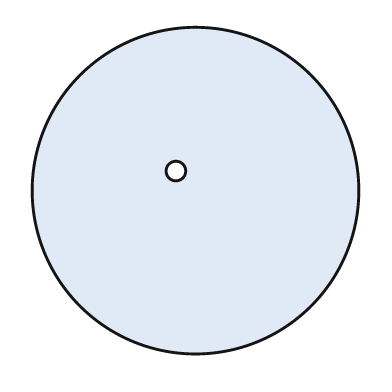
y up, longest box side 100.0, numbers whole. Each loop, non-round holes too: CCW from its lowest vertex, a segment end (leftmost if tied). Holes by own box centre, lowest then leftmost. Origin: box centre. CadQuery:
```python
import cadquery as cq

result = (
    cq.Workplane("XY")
    .moveTo(0.0, 0.0)
    .circle(50.0)
    .moveTo(-6.0, 6.0)
    .circle(3.0)
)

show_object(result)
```